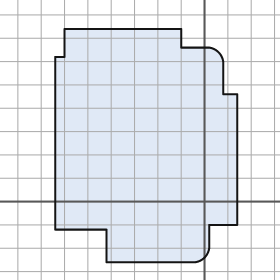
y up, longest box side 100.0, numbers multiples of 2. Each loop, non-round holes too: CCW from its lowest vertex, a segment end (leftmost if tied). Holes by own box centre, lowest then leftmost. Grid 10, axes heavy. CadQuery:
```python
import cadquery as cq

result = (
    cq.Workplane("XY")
    .moveTo(-42.0, -26.0)
    .lineTo(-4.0, -26.0)
    .threePointArc((0.0, -24.0), (2.0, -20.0))
    .lineTo(2.0, -10.0)
    .lineTo(14.0, -10.0)
    .lineTo(14.0, 46.0)
    .lineTo(8.0, 46.0)
    .lineTo(8.0, 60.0)
    .threePointArc((6.0, 64.0), (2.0, 66.0))
    .lineTo(-10.0, 66.0)
    .lineTo(-10.0, 74.0)
    .lineTo(-60.0, 74.0)
    .lineTo(-60.0, 62.0)
    .lineTo(-64.0, 62.0)
    .lineTo(-64.0, -12.0)
    .lineTo(-42.0, -12.0)
    .close()
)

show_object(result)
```